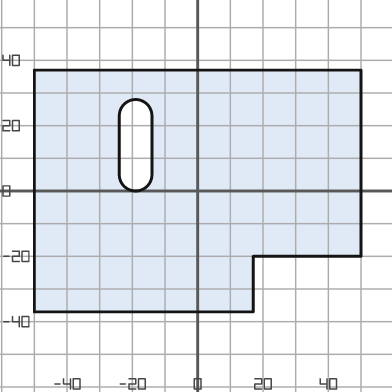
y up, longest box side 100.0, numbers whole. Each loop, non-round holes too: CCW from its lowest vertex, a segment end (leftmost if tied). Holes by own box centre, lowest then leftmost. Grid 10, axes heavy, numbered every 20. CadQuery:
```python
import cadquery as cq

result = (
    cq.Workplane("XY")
    .moveTo(-50.0, -37.0)
    .lineTo(17.0, -37.0)
    .lineTo(17.0, -20.0)
    .lineTo(50.0, -20.0)
    .lineTo(50.0, 37.0)
    .lineTo(-50.0, 37.0)
    .close()
    .moveTo(-24.0, 5.0)
    .threePointArc((-19.0, 0.0), (-14.0, 5.0))
    .lineTo(-14.0, 23.0)
    .threePointArc((-19.0, 28.0), (-24.0, 23.0))
    .close()
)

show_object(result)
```